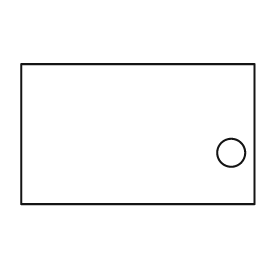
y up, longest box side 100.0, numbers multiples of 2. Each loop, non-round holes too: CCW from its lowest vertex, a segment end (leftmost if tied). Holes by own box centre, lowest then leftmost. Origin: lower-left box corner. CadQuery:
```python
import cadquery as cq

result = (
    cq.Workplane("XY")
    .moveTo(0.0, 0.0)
    .lineTo(100.0, 0.0)
    .lineTo(100.0, 60.0)
    .lineTo(0.0, 60.0)
    .close()
    .moveTo(90.0, 22.0)
    .circle(6.0)
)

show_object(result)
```